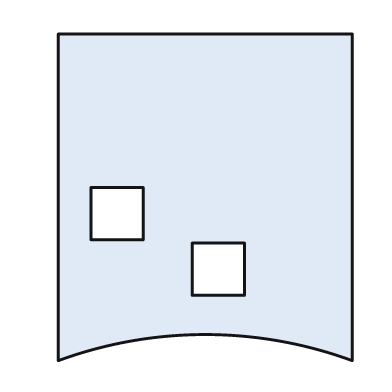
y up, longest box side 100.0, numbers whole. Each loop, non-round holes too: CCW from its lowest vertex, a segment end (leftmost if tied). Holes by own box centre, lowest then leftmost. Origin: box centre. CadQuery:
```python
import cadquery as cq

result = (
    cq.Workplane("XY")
    .moveTo(-45.0, -50.0)
    .threePointArc((0.0, -42.0), (45.0, -50.0))
    .lineTo(45.0, 50.0)
    .lineTo(-45.0, 50.0)
    .close()
    .moveTo(-4.0, -30.0)
    .lineTo(12.0, -30.0)
    .lineTo(12.0, -14.0)
    .lineTo(-4.0, -14.0)
    .close()
    .moveTo(-35.0, -13.0)
    .lineTo(-19.0, -13.0)
    .lineTo(-19.0, 3.0)
    .lineTo(-35.0, 3.0)
    .close()
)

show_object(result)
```